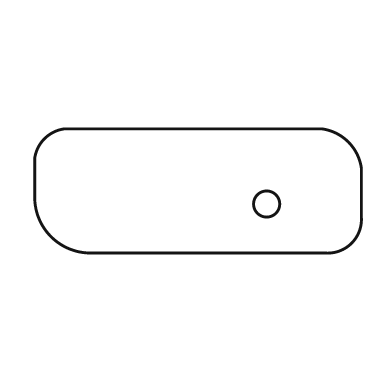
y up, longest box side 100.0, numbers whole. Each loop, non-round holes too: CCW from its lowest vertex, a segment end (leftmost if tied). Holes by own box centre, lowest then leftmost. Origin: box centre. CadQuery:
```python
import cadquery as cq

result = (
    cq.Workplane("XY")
    .moveTo(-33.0, -19.0)
    .lineTo(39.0, -19.0)
    .threePointArc((47.0, -16.0), (50.0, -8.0))
    .lineTo(50.0, 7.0)
    .threePointArc((46.0, 15.0), (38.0, 19.0))
    .lineTo(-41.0, 19.0)
    .threePointArc((-47.0, 16.0), (-50.0, 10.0))
    .lineTo(-50.0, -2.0)
    .threePointArc((-45.0, -14.0), (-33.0, -19.0))
    .close()
    .moveTo(21.0, -4.0)
    .circle(4.0)
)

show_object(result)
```